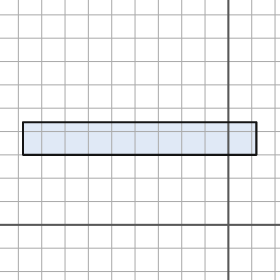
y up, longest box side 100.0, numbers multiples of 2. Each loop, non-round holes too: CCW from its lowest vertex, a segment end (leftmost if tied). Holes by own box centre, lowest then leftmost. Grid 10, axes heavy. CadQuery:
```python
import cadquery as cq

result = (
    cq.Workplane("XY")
    .moveTo(-88.0, 30.0)
    .lineTo(12.0, 30.0)
    .lineTo(12.0, 44.0)
    .lineTo(-88.0, 44.0)
    .close()
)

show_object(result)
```